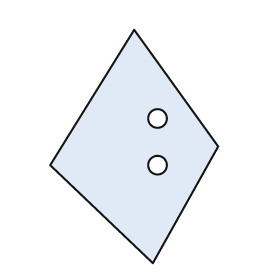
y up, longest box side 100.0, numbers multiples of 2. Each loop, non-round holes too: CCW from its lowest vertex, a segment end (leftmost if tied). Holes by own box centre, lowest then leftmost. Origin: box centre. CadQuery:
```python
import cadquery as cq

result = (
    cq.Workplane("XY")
    .moveTo(8.0, -50.0)
    .lineTo(36.0, 0.0)
    .lineTo(0.0, 50.0)
    .lineTo(-36.0, -8.0)
    .close()
    .moveTo(10.0, -8.0)
    .circle(4.0)
    .moveTo(10.0, 12.0)
    .circle(4.0)
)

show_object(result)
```